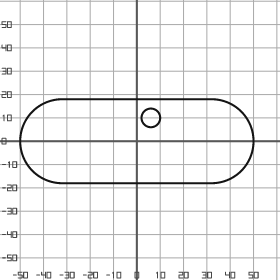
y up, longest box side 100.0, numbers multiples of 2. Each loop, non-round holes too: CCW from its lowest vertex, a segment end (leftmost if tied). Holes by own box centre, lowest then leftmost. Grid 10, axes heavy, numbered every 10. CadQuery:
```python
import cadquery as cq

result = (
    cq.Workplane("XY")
    .moveTo(-32.0, -18.0)
    .lineTo(32.0, -18.0)
    .threePointArc((50.0, 0.0), (32.0, 18.0))
    .lineTo(-32.0, 18.0)
    .threePointArc((-50.0, 0.0), (-32.0, -18.0))
    .close()
    .moveTo(6.0, 10.0)
    .circle(4.0)
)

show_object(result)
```